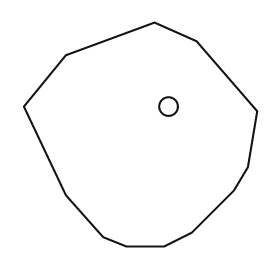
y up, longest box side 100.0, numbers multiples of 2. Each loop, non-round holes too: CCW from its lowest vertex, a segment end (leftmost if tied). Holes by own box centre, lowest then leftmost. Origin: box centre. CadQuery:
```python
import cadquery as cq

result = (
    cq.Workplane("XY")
    .moveTo(-6.0, -48.0)
    .lineTo(10.0, -48.0)
    .lineTo(22.0, -42.0)
    .lineTo(40.0, -24.0)
    .lineTo(46.0, -14.0)
    .lineTo(50.0, 10.0)
    .lineTo(24.0, 40.0)
    .lineTo(6.0, 48.0)
    .lineTo(-32.0, 34.0)
    .lineTo(-50.0, 12.0)
    .lineTo(-32.0, -26.0)
    .lineTo(-16.0, -44.0)
    .close()
    .moveTo(12.0, 12.0)
    .circle(4.0)
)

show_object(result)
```